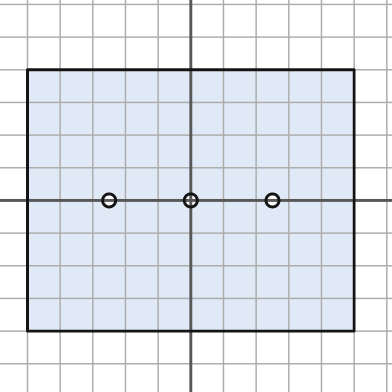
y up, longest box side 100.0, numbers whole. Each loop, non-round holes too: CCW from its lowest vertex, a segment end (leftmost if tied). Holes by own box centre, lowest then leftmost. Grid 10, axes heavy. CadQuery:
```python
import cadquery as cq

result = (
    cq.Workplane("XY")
    .moveTo(-50.0, -40.0)
    .lineTo(50.0, -40.0)
    .lineTo(50.0, 40.0)
    .lineTo(-50.0, 40.0)
    .close()
    .moveTo(-25.0, 0.0)
    .circle(2.0)
    .moveTo(0.0, 0.0)
    .circle(2.0)
    .moveTo(25.0, 0.0)
    .circle(2.0)
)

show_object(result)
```